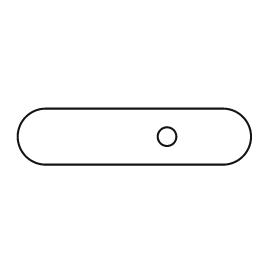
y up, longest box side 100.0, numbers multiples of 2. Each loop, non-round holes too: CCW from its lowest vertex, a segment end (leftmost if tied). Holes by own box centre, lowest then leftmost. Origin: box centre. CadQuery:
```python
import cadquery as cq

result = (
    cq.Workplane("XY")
    .moveTo(-38.0, -12.0)
    .lineTo(38.0, -12.0)
    .threePointArc((50.0, 0.0), (38.0, 12.0))
    .lineTo(-38.0, 12.0)
    .threePointArc((-50.0, 0.0), (-38.0, -12.0))
    .close()
    .moveTo(14.0, 0.0)
    .circle(4.0)
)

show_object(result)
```